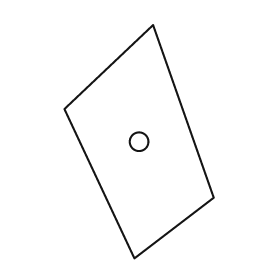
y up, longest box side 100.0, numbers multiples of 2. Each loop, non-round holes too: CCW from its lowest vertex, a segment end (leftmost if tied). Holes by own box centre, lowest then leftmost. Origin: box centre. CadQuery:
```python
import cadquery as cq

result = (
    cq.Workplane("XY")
    .moveTo(-2.0, -50.0)
    .lineTo(32.0, -24.0)
    .lineTo(6.0, 50.0)
    .lineTo(-32.0, 14.0)
    .close()
    .moveTo(0.0, 0.0)
    .circle(4.0)
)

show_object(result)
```